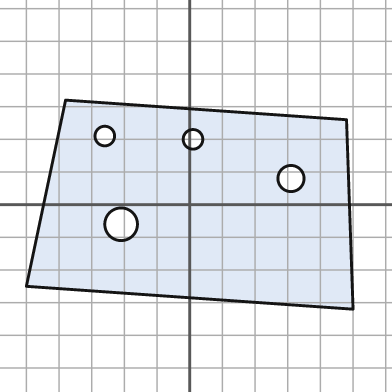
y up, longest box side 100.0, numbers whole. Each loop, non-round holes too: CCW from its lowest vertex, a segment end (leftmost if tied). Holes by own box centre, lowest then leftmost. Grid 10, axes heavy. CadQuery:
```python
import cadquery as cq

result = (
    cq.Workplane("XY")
    .moveTo(50.0, -32.0)
    .lineTo(48.0, 26.0)
    .lineTo(-38.0, 32.0)
    .lineTo(-50.0, -25.0)
    .close()
    .moveTo(-21.0, -6.0)
    .circle(5.0)
    .moveTo(31.0, 8.0)
    .circle(4.0)
    .moveTo(1.0, 20.0)
    .circle(3.0)
    .moveTo(-26.0, 21.0)
    .circle(3.0)
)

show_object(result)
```